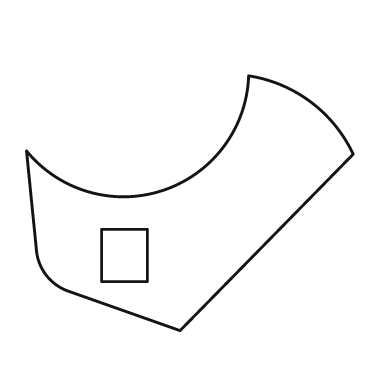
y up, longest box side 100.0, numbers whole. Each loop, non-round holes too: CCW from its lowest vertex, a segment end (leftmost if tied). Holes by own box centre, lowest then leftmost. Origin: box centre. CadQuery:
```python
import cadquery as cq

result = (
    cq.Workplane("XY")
    .moveTo(-3.0, -39.0)
    .lineTo(50.0, 15.0)
    .threePointArc((37.0, 31.0), (18.0, 39.0))
    .threePointArc((-8.0, 4.0), (-50.0, 16.0))
    .lineTo(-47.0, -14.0)
    .threePointArc((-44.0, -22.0), (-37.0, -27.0))
    .close()
    .moveTo(-27.0, -24.0)
    .lineTo(-13.0, -24.0)
    .lineTo(-13.0, -8.0)
    .lineTo(-27.0, -8.0)
    .close()
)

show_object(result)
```